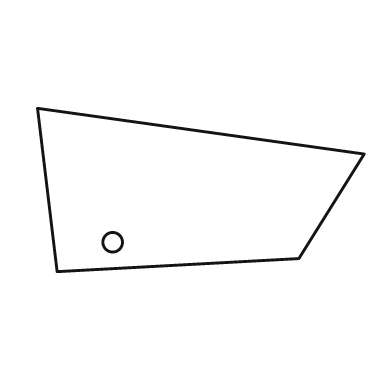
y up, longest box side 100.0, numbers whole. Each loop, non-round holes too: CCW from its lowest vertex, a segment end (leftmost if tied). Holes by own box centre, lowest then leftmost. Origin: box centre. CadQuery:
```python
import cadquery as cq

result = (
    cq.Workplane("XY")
    .moveTo(-44.0, -25.0)
    .lineTo(30.0, -21.0)
    .lineTo(50.0, 11.0)
    .lineTo(-50.0, 25.0)
    .close()
    .moveTo(-27.0, -16.0)
    .circle(3.0)
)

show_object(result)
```